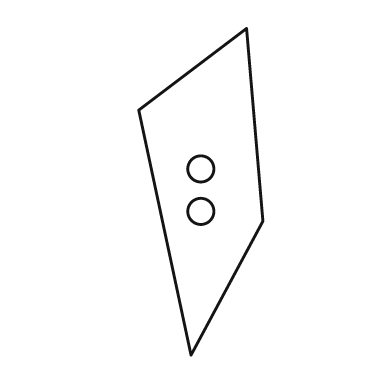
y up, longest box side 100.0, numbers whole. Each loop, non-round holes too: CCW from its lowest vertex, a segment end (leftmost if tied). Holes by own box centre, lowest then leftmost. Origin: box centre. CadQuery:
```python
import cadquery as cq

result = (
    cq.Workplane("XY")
    .moveTo(-3.0, -50.0)
    .lineTo(19.0, -9.0)
    .lineTo(14.0, 50.0)
    .lineTo(-19.0, 25.0)
    .close()
    .moveTo(0.0, -6.0)
    .circle(4.0)
    .moveTo(0.0, 7.0)
    .circle(4.0)
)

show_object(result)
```